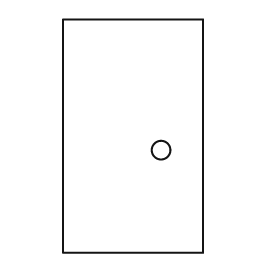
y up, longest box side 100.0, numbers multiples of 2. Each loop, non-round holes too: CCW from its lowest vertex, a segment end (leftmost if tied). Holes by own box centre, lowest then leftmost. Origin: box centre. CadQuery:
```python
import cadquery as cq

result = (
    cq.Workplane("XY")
    .moveTo(-30.0, -50.0)
    .lineTo(30.0, -50.0)
    .lineTo(30.0, 50.0)
    .lineTo(-30.0, 50.0)
    .close()
    .moveTo(12.0, -6.0)
    .circle(4.0)
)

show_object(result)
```